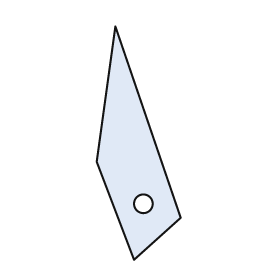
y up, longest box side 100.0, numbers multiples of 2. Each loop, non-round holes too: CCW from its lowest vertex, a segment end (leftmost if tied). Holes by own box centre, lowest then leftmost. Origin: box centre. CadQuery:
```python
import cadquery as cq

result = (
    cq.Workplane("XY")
    .moveTo(-2.0, -50.0)
    .lineTo(18.0, -32.0)
    .lineTo(-10.0, 50.0)
    .lineTo(-18.0, -8.0)
    .close()
    .moveTo(2.0, -26.0)
    .circle(4.0)
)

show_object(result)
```